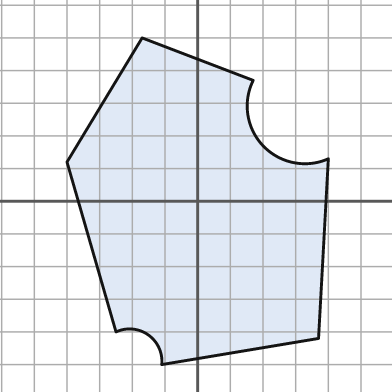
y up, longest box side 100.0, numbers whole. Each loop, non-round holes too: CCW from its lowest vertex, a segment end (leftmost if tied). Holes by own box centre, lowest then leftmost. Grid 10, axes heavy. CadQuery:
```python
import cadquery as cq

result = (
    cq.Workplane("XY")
    .moveTo(-11.0, -50.0)
    .lineTo(37.0, -42.0)
    .lineTo(40.0, 13.0)
    .threePointArc((20.0, 17.0), (17.0, 37.0))
    .lineTo(-17.0, 50.0)
    .lineTo(-40.0, 12.0)
    .lineTo(-25.0, -40.0)
    .threePointArc((-15.0, -41.0), (-11.0, -50.0))
    .close()
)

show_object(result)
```